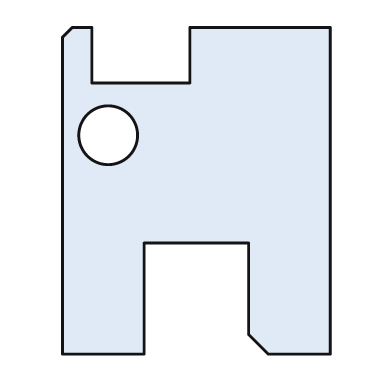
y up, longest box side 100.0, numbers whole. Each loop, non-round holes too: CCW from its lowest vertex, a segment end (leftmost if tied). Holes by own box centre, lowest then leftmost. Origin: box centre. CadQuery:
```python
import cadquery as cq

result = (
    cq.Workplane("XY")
    .moveTo(-41.0, -50.0)
    .lineTo(-16.0, -50.0)
    .lineTo(-16.0, -16.0)
    .lineTo(16.0, -16.0)
    .lineTo(16.0, -44.0)
    .lineTo(22.0, -50.0)
    .lineTo(41.0, -50.0)
    .lineTo(41.0, 50.0)
    .lineTo(-2.0, 50.0)
    .lineTo(-2.0, 33.0)
    .lineTo(-32.0, 33.0)
    .lineTo(-32.0, 50.0)
    .lineTo(-38.0, 50.0)
    .lineTo(-41.0, 47.0)
    .close()
    .moveTo(-27.0, 17.0)
    .circle(9.0)
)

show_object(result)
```